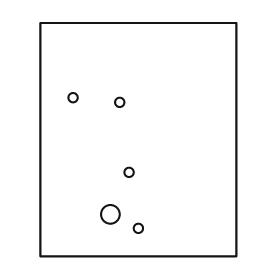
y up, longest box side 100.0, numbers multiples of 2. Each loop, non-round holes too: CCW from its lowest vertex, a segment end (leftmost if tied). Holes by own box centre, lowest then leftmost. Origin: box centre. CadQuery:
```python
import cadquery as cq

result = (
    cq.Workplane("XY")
    .moveTo(-42.0, -50.0)
    .lineTo(42.0, -50.0)
    .lineTo(42.0, 50.0)
    .lineTo(-42.0, 50.0)
    .close()
    .moveTo(0.0, -38.0)
    .circle(2.0)
    .moveTo(-12.0, -32.0)
    .circle(4.0)
    .moveTo(-4.0, -14.0)
    .circle(2.0)
    .moveTo(-8.0, 16.0)
    .circle(2.0)
    .moveTo(-28.0, 18.0)
    .circle(2.0)
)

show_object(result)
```